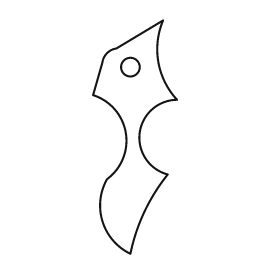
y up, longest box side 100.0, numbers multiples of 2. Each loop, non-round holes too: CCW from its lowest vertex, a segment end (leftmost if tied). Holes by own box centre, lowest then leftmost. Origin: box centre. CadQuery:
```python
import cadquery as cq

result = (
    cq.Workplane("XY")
    .moveTo(-2.0, -50.0)
    .threePointArc((4.0, -32.0), (14.0, -16.0))
    .threePointArc((2.0, 2.0), (18.0, 16.0))
    .threePointArc((10.0, 32.0), (12.0, 50.0))
    .lineTo(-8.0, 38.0)
    .threePointArc((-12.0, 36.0), (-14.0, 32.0))
    .lineTo(-18.0, 18.0)
    .threePointArc((-4.0, 2.0), (-12.0, -18.0))
    .threePointArc((-14.0, -36.0), (-2.0, -50.0))
    .close()
    .moveTo(-2.0, 30.0)
    .circle(4.0)
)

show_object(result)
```